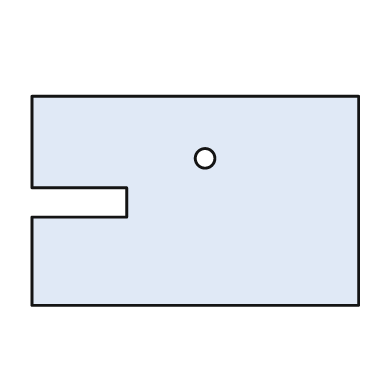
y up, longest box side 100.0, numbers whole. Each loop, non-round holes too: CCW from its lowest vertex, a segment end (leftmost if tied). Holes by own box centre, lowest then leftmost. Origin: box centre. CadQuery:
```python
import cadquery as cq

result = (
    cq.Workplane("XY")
    .moveTo(-50.0, -32.0)
    .lineTo(50.0, -32.0)
    .lineTo(50.0, 32.0)
    .lineTo(-50.0, 32.0)
    .lineTo(-50.0, 4.0)
    .lineTo(-21.0, 4.0)
    .lineTo(-21.0, -5.0)
    .lineTo(-50.0, -5.0)
    .close()
    .moveTo(3.0, 13.0)
    .circle(3.0)
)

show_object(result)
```